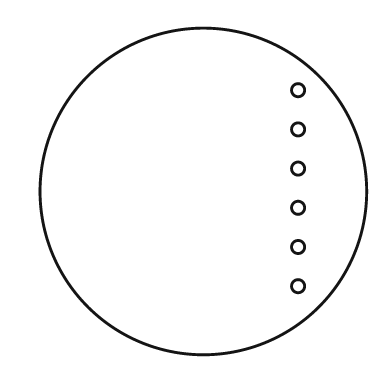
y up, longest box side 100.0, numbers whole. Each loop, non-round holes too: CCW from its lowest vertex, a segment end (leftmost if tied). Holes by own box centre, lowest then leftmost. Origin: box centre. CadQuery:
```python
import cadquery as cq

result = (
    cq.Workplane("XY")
    .moveTo(0.0, 0.0)
    .circle(50.0)
    .moveTo(29.0, -29.0)
    .circle(2.0)
    .moveTo(29.0, -17.0)
    .circle(2.0)
    .moveTo(29.0, -5.0)
    .circle(2.0)
    .moveTo(29.0, 7.0)
    .circle(2.0)
    .moveTo(29.0, 19.0)
    .circle(2.0)
    .moveTo(29.0, 31.0)
    .circle(2.0)
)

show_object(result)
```